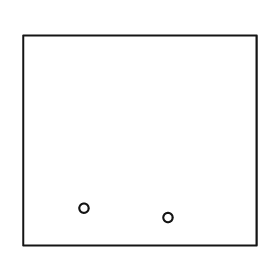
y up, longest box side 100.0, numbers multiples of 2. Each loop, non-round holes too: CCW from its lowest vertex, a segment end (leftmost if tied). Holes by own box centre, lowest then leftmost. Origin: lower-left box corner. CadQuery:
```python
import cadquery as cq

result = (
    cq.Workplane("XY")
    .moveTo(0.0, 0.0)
    .lineTo(100.0, 0.0)
    .lineTo(100.0, 90.0)
    .lineTo(0.0, 90.0)
    .close()
    .moveTo(62.0, 12.0)
    .circle(2.0)
    .moveTo(26.0, 16.0)
    .circle(2.0)
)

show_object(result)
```